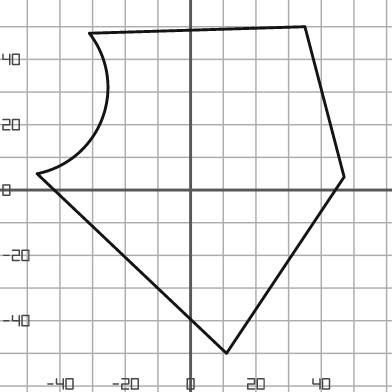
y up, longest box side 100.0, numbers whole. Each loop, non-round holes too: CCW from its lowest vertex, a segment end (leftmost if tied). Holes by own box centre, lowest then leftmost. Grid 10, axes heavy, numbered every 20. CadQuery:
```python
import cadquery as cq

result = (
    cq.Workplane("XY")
    .moveTo(11.0, -50.0)
    .lineTo(47.0, 4.0)
    .lineTo(35.0, 50.0)
    .lineTo(-31.0, 48.0)
    .threePointArc((-27.0, 22.0), (-47.0, 5.0))
    .close()
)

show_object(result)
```